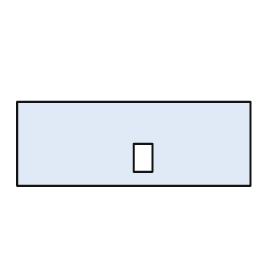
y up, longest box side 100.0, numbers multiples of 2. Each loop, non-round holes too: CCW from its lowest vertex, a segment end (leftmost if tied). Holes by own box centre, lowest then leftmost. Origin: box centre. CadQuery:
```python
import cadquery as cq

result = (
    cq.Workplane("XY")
    .moveTo(-50.0, -18.0)
    .lineTo(50.0, -18.0)
    .lineTo(50.0, 18.0)
    .lineTo(-50.0, 18.0)
    .close()
    .moveTo(0.0, -12.0)
    .lineTo(8.0, -12.0)
    .lineTo(8.0, 0.0)
    .lineTo(0.0, 0.0)
    .close()
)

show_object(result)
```